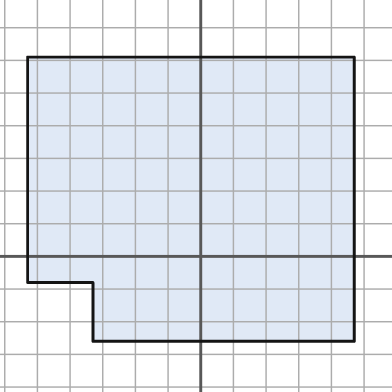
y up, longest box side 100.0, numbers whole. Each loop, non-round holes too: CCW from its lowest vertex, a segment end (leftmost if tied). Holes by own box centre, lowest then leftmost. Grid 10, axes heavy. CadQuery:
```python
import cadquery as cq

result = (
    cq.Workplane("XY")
    .moveTo(-33.0, -26.0)
    .lineTo(47.0, -26.0)
    .lineTo(47.0, 61.0)
    .lineTo(-53.0, 61.0)
    .lineTo(-53.0, -8.0)
    .lineTo(-33.0, -8.0)
    .close()
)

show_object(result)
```